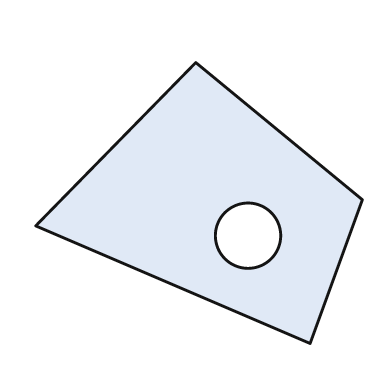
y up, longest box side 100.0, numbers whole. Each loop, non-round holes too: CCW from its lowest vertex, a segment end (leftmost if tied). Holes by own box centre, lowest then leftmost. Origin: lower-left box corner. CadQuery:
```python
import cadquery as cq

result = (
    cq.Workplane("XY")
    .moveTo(84.0, 0.0)
    .lineTo(100.0, 44.0)
    .lineTo(49.0, 86.0)
    .lineTo(0.0, 36.0)
    .close()
    .moveTo(65.0, 33.0)
    .circle(10.0)
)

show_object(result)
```